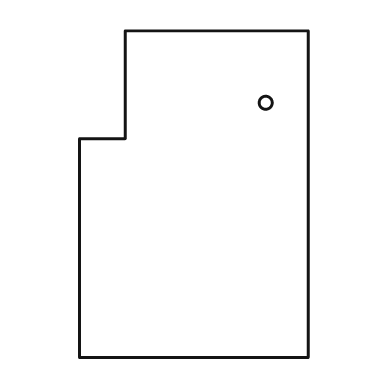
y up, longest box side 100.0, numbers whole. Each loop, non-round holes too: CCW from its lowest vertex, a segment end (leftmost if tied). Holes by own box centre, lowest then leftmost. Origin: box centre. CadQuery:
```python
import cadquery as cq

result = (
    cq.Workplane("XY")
    .moveTo(-35.0, -50.0)
    .lineTo(35.0, -50.0)
    .lineTo(35.0, 50.0)
    .lineTo(-21.0, 50.0)
    .lineTo(-21.0, 17.0)
    .lineTo(-35.0, 17.0)
    .close()
    .moveTo(22.0, 28.0)
    .circle(2.0)
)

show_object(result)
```